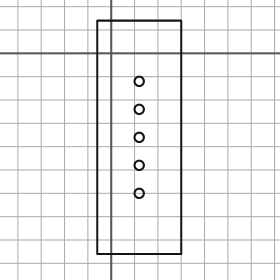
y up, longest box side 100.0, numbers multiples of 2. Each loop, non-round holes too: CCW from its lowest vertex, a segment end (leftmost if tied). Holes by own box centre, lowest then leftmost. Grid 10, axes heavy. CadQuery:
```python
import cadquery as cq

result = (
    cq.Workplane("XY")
    .moveTo(-6.0, -86.0)
    .lineTo(30.0, -86.0)
    .lineTo(30.0, 14.0)
    .lineTo(-6.0, 14.0)
    .close()
    .moveTo(12.0, -60.0)
    .circle(2.0)
    .moveTo(12.0, -48.0)
    .circle(2.0)
    .moveTo(12.0, -36.0)
    .circle(2.0)
    .moveTo(12.0, -24.0)
    .circle(2.0)
    .moveTo(12.0, -12.0)
    .circle(2.0)
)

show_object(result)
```